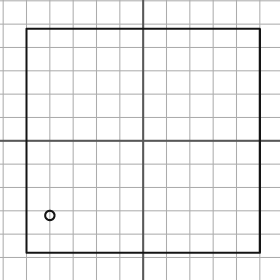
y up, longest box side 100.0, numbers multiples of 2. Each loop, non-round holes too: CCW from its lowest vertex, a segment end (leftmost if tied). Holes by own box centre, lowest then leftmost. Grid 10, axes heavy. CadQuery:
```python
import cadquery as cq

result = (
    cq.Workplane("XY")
    .moveTo(-50.0, -48.0)
    .lineTo(50.0, -48.0)
    .lineTo(50.0, 48.0)
    .lineTo(-50.0, 48.0)
    .close()
    .moveTo(-40.0, -32.0)
    .circle(2.0)
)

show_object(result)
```